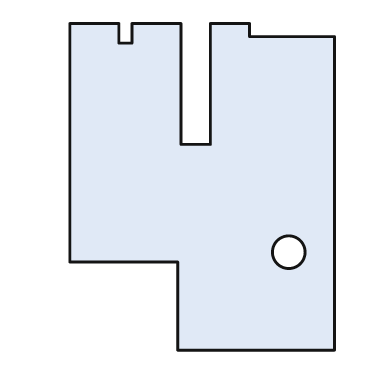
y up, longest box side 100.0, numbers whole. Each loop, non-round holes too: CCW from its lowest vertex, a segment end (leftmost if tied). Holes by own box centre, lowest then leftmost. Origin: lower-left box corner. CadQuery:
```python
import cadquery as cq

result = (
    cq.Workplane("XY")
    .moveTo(33.0, 0.0)
    .lineTo(81.0, 0.0)
    .lineTo(81.0, 96.0)
    .lineTo(55.0, 96.0)
    .lineTo(55.0, 100.0)
    .lineTo(43.0, 100.0)
    .lineTo(43.0, 63.0)
    .lineTo(34.0, 63.0)
    .lineTo(34.0, 100.0)
    .lineTo(19.0, 100.0)
    .lineTo(19.0, 94.0)
    .lineTo(15.0, 94.0)
    .lineTo(15.0, 100.0)
    .lineTo(0.0, 100.0)
    .lineTo(0.0, 27.0)
    .lineTo(33.0, 27.0)
    .close()
    .moveTo(67.0, 30.0)
    .circle(5.0)
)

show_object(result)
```